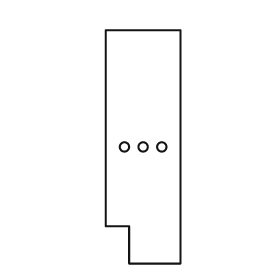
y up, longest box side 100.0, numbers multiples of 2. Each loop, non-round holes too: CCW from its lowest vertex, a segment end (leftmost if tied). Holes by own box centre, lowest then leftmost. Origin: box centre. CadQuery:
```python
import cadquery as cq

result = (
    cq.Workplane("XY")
    .moveTo(-6.0, -50.0)
    .lineTo(16.0, -50.0)
    .lineTo(16.0, 50.0)
    .lineTo(-16.0, 50.0)
    .lineTo(-16.0, -34.0)
    .lineTo(-6.0, -34.0)
    .close()
    .moveTo(-8.0, 0.0)
    .circle(2.0)
    .moveTo(0.0, 0.0)
    .circle(2.0)
    .moveTo(8.0, 0.0)
    .circle(2.0)
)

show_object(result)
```